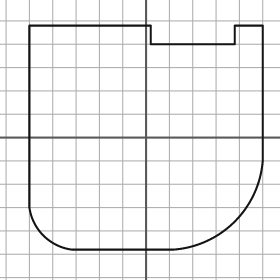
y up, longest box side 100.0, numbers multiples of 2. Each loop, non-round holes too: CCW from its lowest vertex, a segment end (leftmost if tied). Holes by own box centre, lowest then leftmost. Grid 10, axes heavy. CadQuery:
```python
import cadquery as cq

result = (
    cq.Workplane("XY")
    .moveTo(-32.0, -48.0)
    .lineTo(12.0, -48.0)
    .threePointArc((38.0, -36.0), (50.0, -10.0))
    .lineTo(50.0, 48.0)
    .lineTo(38.0, 48.0)
    .lineTo(38.0, 40.0)
    .lineTo(2.0, 40.0)
    .lineTo(2.0, 48.0)
    .lineTo(-50.0, 48.0)
    .lineTo(-50.0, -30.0)
    .threePointArc((-44.0, -42.0), (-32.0, -48.0))
    .close()
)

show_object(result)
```